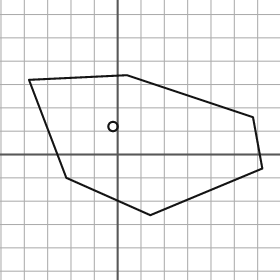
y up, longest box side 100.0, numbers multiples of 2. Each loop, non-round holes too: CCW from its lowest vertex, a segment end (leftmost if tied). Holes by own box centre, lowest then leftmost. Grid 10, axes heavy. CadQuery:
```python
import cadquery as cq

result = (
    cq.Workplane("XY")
    .moveTo(14.0, -26.0)
    .lineTo(62.0, -6.0)
    .lineTo(58.0, 16.0)
    .lineTo(4.0, 34.0)
    .lineTo(-38.0, 32.0)
    .lineTo(-22.0, -10.0)
    .close()
    .moveTo(-2.0, 12.0)
    .circle(2.0)
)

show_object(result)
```